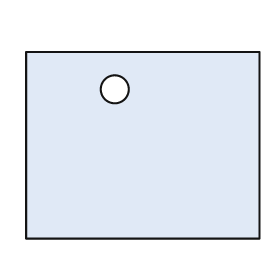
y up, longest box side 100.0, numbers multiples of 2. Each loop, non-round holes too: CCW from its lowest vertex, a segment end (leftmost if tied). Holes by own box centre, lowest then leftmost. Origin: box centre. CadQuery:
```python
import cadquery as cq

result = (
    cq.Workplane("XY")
    .moveTo(-50.0, -40.0)
    .lineTo(50.0, -40.0)
    .lineTo(50.0, 40.0)
    .lineTo(-50.0, 40.0)
    .close()
    .moveTo(-12.0, 24.0)
    .circle(6.0)
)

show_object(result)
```